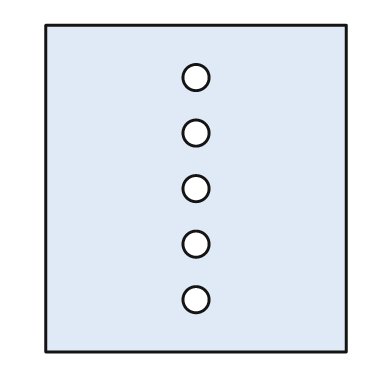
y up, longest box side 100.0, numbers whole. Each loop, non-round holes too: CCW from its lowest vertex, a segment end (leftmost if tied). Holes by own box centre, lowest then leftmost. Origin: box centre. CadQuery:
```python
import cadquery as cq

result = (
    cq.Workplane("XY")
    .moveTo(-46.0, -50.0)
    .lineTo(46.0, -50.0)
    .lineTo(46.0, 50.0)
    .lineTo(-46.0, 50.0)
    .close()
    .moveTo(0.0, -34.0)
    .circle(4.0)
    .moveTo(0.0, -17.0)
    .circle(4.0)
    .moveTo(0.0, 0.0)
    .circle(4.0)
    .moveTo(0.0, 17.0)
    .circle(4.0)
    .moveTo(0.0, 34.0)
    .circle(4.0)
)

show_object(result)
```